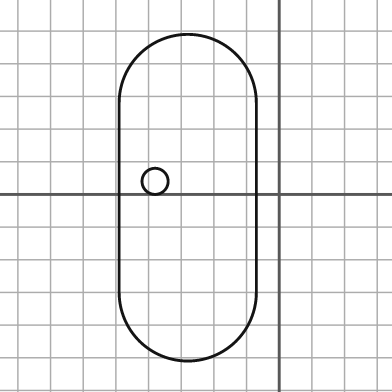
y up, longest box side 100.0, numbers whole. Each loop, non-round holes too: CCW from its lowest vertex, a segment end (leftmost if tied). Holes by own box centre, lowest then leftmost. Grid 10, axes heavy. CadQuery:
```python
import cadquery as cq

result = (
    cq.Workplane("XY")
    .moveTo(-49.0, -30.0)
    .threePointArc((-28.0, -51.0), (-7.0, -30.0))
    .lineTo(-7.0, 28.0)
    .threePointArc((-28.0, 49.0), (-49.0, 28.0))
    .close()
    .moveTo(-38.0, 4.0)
    .circle(4.0)
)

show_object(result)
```